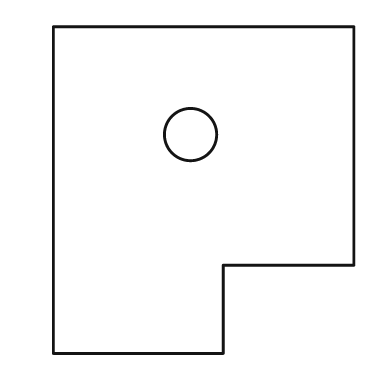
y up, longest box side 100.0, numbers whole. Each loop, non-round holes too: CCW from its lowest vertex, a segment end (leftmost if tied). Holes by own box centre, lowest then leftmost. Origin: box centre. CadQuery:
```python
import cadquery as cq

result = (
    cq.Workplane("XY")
    .moveTo(-46.0, -50.0)
    .lineTo(6.0, -50.0)
    .lineTo(6.0, -23.0)
    .lineTo(46.0, -23.0)
    .lineTo(46.0, 50.0)
    .lineTo(-46.0, 50.0)
    .close()
    .moveTo(-4.0, 17.0)
    .circle(8.0)
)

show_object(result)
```